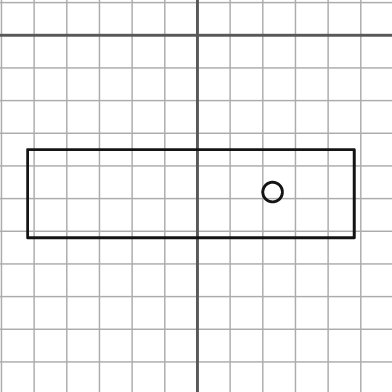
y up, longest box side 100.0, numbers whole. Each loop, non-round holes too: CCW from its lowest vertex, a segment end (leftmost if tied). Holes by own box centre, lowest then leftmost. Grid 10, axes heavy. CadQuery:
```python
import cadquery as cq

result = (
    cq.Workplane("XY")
    .moveTo(-52.0, -62.0)
    .lineTo(48.0, -62.0)
    .lineTo(48.0, -35.0)
    .lineTo(-52.0, -35.0)
    .close()
    .moveTo(23.0, -48.0)
    .circle(3.0)
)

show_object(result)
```